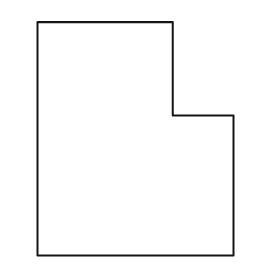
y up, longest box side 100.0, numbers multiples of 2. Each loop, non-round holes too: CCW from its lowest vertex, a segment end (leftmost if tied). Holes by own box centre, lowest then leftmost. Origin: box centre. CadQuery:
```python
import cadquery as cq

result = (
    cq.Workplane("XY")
    .moveTo(-42.0, -50.0)
    .lineTo(42.0, -50.0)
    .lineTo(42.0, 10.0)
    .lineTo(16.0, 10.0)
    .lineTo(16.0, 50.0)
    .lineTo(-42.0, 50.0)
    .close()
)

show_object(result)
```